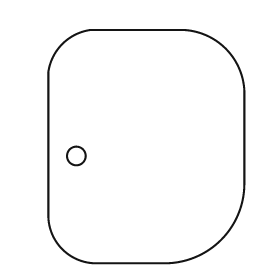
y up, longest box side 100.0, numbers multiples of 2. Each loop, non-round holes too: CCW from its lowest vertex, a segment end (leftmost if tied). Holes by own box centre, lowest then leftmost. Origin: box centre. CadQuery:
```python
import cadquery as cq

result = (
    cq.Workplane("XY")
    .moveTo(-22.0, -50.0)
    .lineTo(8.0, -50.0)
    .threePointArc((32.0, -40.0), (42.0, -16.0))
    .lineTo(42.0, 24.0)
    .threePointArc((34.0, 42.0), (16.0, 50.0))
    .lineTo(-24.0, 50.0)
    .threePointArc((-36.0, 44.0), (-42.0, 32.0))
    .lineTo(-42.0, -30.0)
    .threePointArc((-36.0, -44.0), (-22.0, -50.0))
    .close()
    .moveTo(-30.0, -4.0)
    .circle(4.0)
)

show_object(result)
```